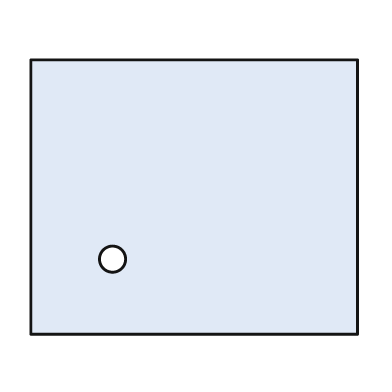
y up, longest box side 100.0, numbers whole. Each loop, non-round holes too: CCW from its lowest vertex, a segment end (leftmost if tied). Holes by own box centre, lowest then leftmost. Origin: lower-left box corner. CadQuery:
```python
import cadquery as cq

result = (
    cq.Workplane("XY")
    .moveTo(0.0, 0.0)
    .lineTo(100.0, 0.0)
    .lineTo(100.0, 84.0)
    .lineTo(0.0, 84.0)
    .close()
    .moveTo(25.0, 23.0)
    .circle(4.0)
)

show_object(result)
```